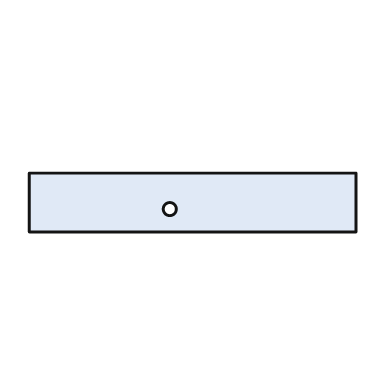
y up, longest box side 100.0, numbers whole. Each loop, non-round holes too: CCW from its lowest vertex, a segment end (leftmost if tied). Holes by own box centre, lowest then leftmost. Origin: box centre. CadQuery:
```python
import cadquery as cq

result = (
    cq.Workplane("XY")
    .moveTo(-50.0, -9.0)
    .lineTo(50.0, -9.0)
    .lineTo(50.0, 9.0)
    .lineTo(-50.0, 9.0)
    .close()
    .moveTo(-7.0, -2.0)
    .circle(2.0)
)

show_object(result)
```